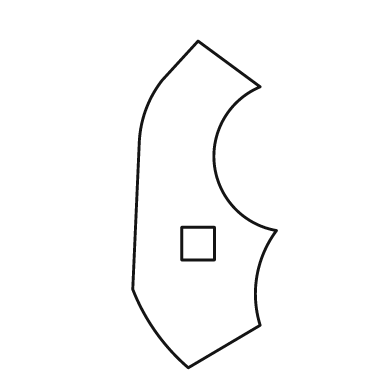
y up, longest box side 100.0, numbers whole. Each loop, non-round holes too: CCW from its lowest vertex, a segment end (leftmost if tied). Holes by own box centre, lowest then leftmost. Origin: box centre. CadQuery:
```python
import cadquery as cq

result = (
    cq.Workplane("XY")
    .moveTo(-5.0, -50.0)
    .lineTo(17.0, -37.0)
    .threePointArc((16.0, -22.0), (22.0, -8.0))
    .threePointArc((3.0, 12.0), (17.0, 36.0))
    .lineTo(-2.0, 50.0)
    .lineTo(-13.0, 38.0)
    .threePointArc((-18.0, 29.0), (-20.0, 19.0))
    .lineTo(-22.0, -26.0)
    .threePointArc((-15.0, -39.0), (-5.0, -50.0))
    .close()
    .moveTo(-7.0, -17.0)
    .lineTo(3.0, -17.0)
    .lineTo(3.0, -7.0)
    .lineTo(-7.0, -7.0)
    .close()
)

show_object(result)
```